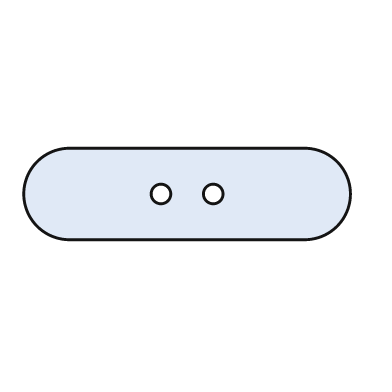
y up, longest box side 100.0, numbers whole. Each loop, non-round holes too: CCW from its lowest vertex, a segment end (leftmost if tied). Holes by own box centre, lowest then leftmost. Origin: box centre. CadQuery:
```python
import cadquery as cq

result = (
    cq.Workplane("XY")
    .moveTo(-36.0, -14.0)
    .lineTo(36.0, -14.0)
    .threePointArc((50.0, 0.0), (36.0, 14.0))
    .lineTo(-36.0, 14.0)
    .threePointArc((-50.0, 0.0), (-36.0, -14.0))
    .close()
    .moveTo(-8.0, 0.0)
    .circle(3.0)
    .moveTo(8.0, 0.0)
    .circle(3.0)
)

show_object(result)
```